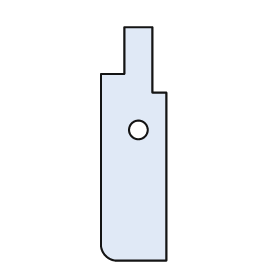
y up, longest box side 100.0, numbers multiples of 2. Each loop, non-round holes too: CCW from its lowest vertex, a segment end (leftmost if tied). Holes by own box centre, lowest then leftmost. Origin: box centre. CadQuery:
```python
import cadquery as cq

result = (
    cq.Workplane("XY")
    .moveTo(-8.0, -50.0)
    .lineTo(14.0, -50.0)
    .lineTo(14.0, 22.0)
    .lineTo(8.0, 22.0)
    .lineTo(8.0, 50.0)
    .lineTo(-4.0, 50.0)
    .lineTo(-4.0, 30.0)
    .lineTo(-14.0, 30.0)
    .lineTo(-14.0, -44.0)
    .threePointArc((-12.0, -48.0), (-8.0, -50.0))
    .close()
    .moveTo(2.0, 6.0)
    .circle(4.0)
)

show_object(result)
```